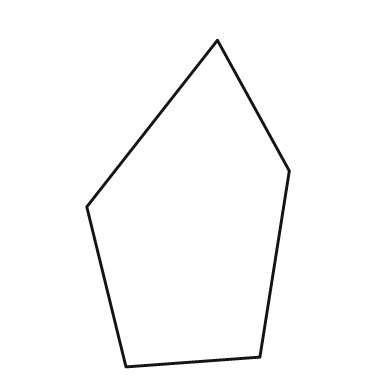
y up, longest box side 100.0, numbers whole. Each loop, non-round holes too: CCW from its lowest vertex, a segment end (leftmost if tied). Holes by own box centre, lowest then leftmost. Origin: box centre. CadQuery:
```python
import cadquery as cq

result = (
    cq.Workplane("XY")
    .moveTo(-19.0, -50.0)
    .lineTo(22.0, -47.0)
    .lineTo(31.0, 10.0)
    .lineTo(9.0, 50.0)
    .lineTo(-31.0, -1.0)
    .close()
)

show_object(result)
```